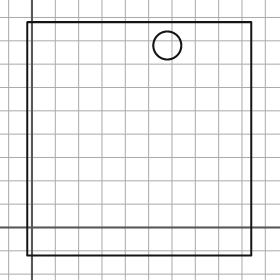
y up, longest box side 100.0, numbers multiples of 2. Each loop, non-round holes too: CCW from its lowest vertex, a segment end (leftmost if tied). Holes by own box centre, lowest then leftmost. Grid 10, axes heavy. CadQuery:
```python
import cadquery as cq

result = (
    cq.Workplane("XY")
    .moveTo(-2.0, -12.0)
    .lineTo(94.0, -12.0)
    .lineTo(94.0, 88.0)
    .lineTo(-2.0, 88.0)
    .close()
    .moveTo(58.0, 78.0)
    .circle(6.0)
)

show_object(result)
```